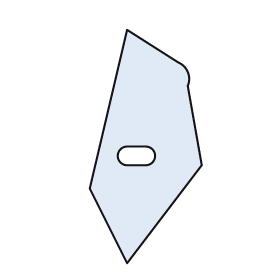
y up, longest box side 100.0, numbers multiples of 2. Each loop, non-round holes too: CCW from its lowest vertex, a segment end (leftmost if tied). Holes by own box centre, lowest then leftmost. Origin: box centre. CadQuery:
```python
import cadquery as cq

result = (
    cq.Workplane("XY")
    .moveTo(-8.0, -50.0)
    .lineTo(24.0, -8.0)
    .lineTo(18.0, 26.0)
    .threePointArc((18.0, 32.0), (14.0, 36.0))
    .lineTo(-8.0, 50.0)
    .lineTo(-24.0, -18.0)
    .close()
    .moveTo(-8.0, -8.0)
    .lineTo(0.0, -8.0)
    .threePointArc((4.0, -4.0), (0.0, 0.0))
    .lineTo(-8.0, 0.0)
    .threePointArc((-12.0, -4.0), (-8.0, -8.0))
    .close()
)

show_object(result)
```